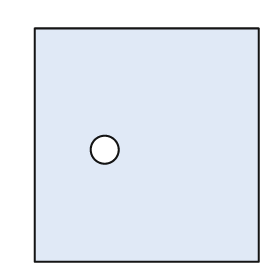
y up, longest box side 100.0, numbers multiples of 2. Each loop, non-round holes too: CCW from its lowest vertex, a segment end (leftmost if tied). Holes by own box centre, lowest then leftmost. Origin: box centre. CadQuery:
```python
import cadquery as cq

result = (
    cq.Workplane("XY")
    .moveTo(-48.0, -50.0)
    .lineTo(48.0, -50.0)
    .lineTo(48.0, 50.0)
    .lineTo(-48.0, 50.0)
    .close()
    .moveTo(-18.0, -2.0)
    .circle(6.0)
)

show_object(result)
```